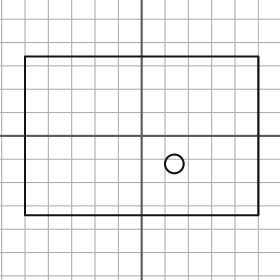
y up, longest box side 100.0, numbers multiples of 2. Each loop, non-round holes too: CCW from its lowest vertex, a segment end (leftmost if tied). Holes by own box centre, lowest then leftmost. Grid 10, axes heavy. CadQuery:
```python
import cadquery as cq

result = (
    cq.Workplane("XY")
    .moveTo(-50.0, -34.0)
    .lineTo(50.0, -34.0)
    .lineTo(50.0, 34.0)
    .lineTo(-50.0, 34.0)
    .close()
    .moveTo(14.0, -12.0)
    .circle(4.0)
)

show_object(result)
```